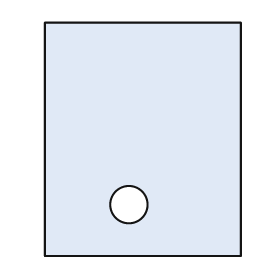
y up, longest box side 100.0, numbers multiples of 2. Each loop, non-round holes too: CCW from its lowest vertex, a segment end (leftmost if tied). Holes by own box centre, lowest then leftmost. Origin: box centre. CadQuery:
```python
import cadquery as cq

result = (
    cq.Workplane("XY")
    .moveTo(-42.0, -50.0)
    .lineTo(42.0, -50.0)
    .lineTo(42.0, 50.0)
    .lineTo(-42.0, 50.0)
    .close()
    .moveTo(-6.0, -28.0)
    .circle(8.0)
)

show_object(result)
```